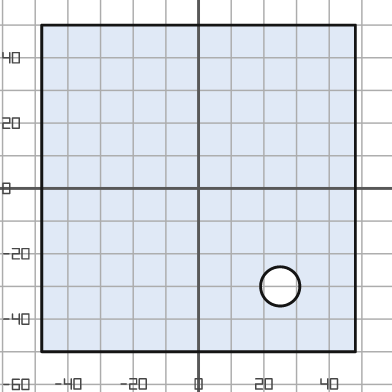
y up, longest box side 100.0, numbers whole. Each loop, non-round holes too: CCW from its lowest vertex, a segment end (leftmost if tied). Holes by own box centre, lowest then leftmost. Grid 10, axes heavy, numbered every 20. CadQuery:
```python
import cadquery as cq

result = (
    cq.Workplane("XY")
    .moveTo(-48.0, -50.0)
    .lineTo(48.0, -50.0)
    .lineTo(48.0, 50.0)
    .lineTo(-48.0, 50.0)
    .close()
    .moveTo(25.0, -30.0)
    .circle(6.0)
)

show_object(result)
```